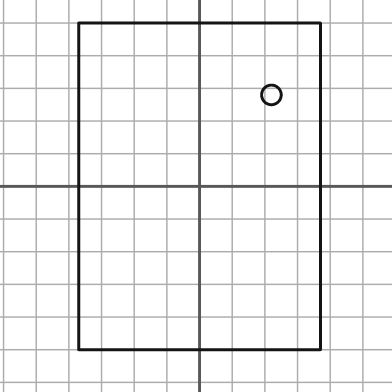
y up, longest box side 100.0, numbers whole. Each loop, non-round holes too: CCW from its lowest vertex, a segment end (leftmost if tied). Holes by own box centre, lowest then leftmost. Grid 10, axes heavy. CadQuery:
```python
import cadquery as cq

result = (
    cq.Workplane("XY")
    .moveTo(-37.0, -50.0)
    .lineTo(37.0, -50.0)
    .lineTo(37.0, 50.0)
    .lineTo(-37.0, 50.0)
    .close()
    .moveTo(22.0, 28.0)
    .circle(3.0)
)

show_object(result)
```